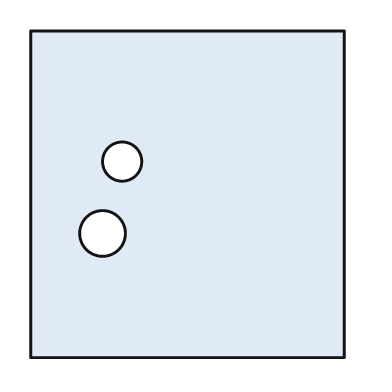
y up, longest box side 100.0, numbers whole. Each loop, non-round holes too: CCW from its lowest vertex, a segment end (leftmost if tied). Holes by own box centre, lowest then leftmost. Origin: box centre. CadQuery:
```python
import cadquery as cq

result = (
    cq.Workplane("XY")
    .moveTo(-48.0, -50.0)
    .lineTo(48.0, -50.0)
    .lineTo(48.0, 50.0)
    .lineTo(-48.0, 50.0)
    .close()
    .moveTo(-26.0, -12.0)
    .circle(7.0)
    .moveTo(-20.0, 10.0)
    .circle(6.0)
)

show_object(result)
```